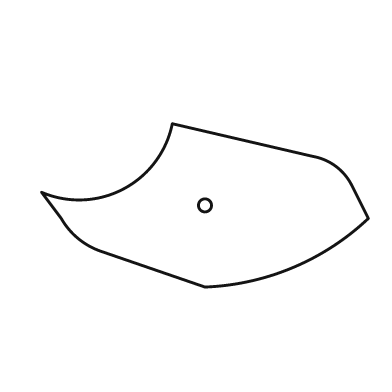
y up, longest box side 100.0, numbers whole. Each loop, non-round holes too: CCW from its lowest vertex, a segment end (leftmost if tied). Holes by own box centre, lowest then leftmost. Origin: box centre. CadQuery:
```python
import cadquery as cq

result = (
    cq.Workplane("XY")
    .moveTo(0.0, -25.0)
    .threePointArc((27.0, -19.0), (50.0, -4.0))
    .lineTo(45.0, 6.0)
    .threePointArc((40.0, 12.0), (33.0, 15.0))
    .lineTo(-10.0, 25.0)
    .threePointArc((-25.0, 5.0), (-50.0, 4.0))
    .lineTo(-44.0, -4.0)
    .threePointArc((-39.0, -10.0), (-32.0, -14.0))
    .close()
    .moveTo(0.0, 0.0)
    .circle(2.0)
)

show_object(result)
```